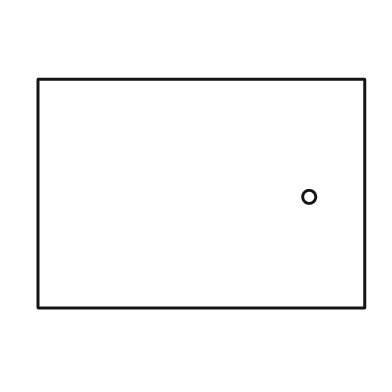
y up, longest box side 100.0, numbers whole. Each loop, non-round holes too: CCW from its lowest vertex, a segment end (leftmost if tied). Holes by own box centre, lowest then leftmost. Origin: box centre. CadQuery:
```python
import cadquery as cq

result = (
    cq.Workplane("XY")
    .moveTo(-50.0, -35.0)
    .lineTo(50.0, -35.0)
    .lineTo(50.0, 35.0)
    .lineTo(-50.0, 35.0)
    .close()
    .moveTo(33.0, -1.0)
    .circle(2.0)
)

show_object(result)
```